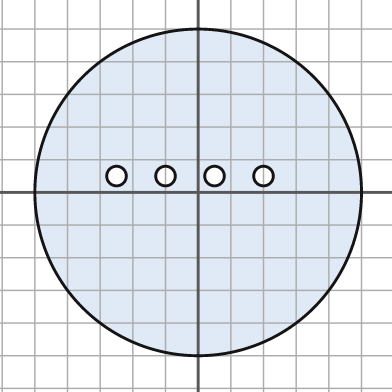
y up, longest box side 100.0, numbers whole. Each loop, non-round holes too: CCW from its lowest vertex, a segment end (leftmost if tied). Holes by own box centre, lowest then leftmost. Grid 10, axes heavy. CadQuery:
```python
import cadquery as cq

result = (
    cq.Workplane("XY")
    .moveTo(0.0, 0.0)
    .circle(50.0)
    .moveTo(-25.0, 5.0)
    .circle(3.0)
    .moveTo(-10.0, 5.0)
    .circle(3.0)
    .moveTo(5.0, 5.0)
    .circle(3.0)
    .moveTo(20.0, 5.0)
    .circle(3.0)
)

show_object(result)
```